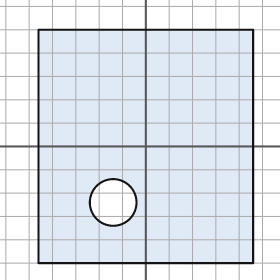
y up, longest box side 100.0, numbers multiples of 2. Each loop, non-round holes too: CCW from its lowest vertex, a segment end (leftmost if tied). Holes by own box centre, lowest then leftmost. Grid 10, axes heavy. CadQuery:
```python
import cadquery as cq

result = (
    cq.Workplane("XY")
    .moveTo(-46.0, -50.0)
    .lineTo(46.0, -50.0)
    .lineTo(46.0, 50.0)
    .lineTo(-46.0, 50.0)
    .close()
    .moveTo(-14.0, -24.0)
    .circle(10.0)
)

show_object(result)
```